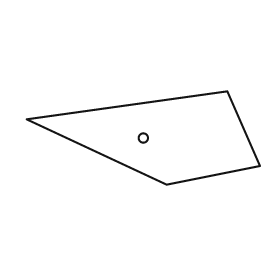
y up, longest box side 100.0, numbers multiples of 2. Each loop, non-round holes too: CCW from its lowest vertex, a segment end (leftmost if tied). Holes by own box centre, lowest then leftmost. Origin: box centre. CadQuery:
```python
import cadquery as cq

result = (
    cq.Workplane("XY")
    .moveTo(10.0, -20.0)
    .lineTo(50.0, -12.0)
    .lineTo(36.0, 20.0)
    .lineTo(-50.0, 8.0)
    .close()
    .moveTo(0.0, 0.0)
    .circle(2.0)
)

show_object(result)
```